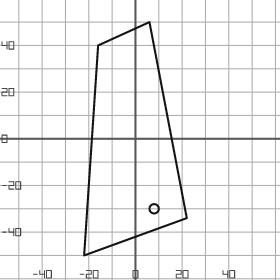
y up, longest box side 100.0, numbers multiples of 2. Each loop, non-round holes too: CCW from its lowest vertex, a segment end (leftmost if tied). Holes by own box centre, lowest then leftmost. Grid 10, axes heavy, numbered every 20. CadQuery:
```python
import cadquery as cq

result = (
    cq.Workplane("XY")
    .moveTo(-22.0, -50.0)
    .lineTo(22.0, -34.0)
    .lineTo(6.0, 50.0)
    .lineTo(-16.0, 40.0)
    .close()
    .moveTo(8.0, -30.0)
    .circle(2.0)
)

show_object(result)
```